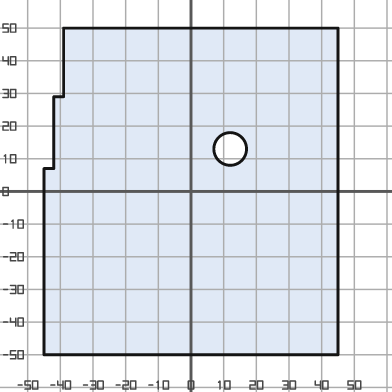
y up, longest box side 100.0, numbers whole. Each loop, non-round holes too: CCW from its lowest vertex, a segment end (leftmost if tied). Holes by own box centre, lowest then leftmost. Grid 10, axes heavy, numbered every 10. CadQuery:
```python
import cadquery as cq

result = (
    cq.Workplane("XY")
    .moveTo(-45.0, -50.0)
    .lineTo(45.0, -50.0)
    .lineTo(45.0, 50.0)
    .lineTo(-39.0, 50.0)
    .lineTo(-39.0, 29.0)
    .lineTo(-42.0, 29.0)
    .lineTo(-42.0, 7.0)
    .lineTo(-45.0, 7.0)
    .close()
    .moveTo(12.0, 13.0)
    .circle(5.0)
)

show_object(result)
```